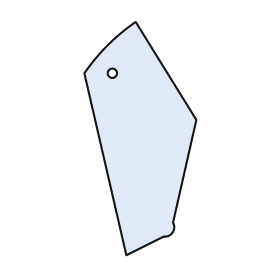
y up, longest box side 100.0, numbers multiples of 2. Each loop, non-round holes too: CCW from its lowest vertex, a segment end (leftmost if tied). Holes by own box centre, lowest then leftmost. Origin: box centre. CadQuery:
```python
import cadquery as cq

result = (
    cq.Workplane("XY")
    .moveTo(-6.0, -50.0)
    .lineTo(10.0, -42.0)
    .threePointArc((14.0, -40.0), (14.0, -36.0))
    .lineTo(24.0, 8.0)
    .lineTo(-2.0, 50.0)
    .threePointArc((-14.0, 40.0), (-24.0, 28.0))
    .close()
    .moveTo(-12.0, 28.0)
    .circle(2.0)
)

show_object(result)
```